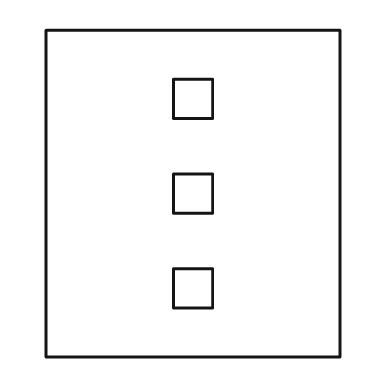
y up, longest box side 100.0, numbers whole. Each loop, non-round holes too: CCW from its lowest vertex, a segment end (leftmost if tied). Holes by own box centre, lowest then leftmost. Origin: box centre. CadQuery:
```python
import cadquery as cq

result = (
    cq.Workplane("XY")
    .moveTo(-45.0, -50.0)
    .lineTo(45.0, -50.0)
    .lineTo(45.0, 50.0)
    .lineTo(-45.0, 50.0)
    .close()
    .moveTo(-6.0, -35.0)
    .lineTo(6.0, -35.0)
    .lineTo(6.0, -23.0)
    .lineTo(-6.0, -23.0)
    .close()
    .moveTo(-6.0, -6.0)
    .lineTo(6.0, -6.0)
    .lineTo(6.0, 6.0)
    .lineTo(-6.0, 6.0)
    .close()
    .moveTo(-6.0, 23.0)
    .lineTo(6.0, 23.0)
    .lineTo(6.0, 35.0)
    .lineTo(-6.0, 35.0)
    .close()
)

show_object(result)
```